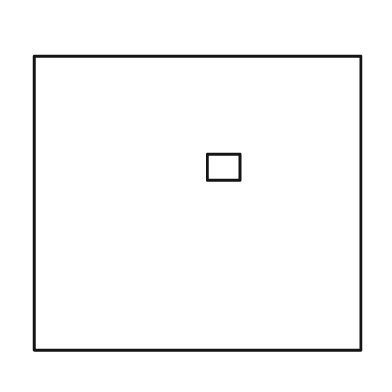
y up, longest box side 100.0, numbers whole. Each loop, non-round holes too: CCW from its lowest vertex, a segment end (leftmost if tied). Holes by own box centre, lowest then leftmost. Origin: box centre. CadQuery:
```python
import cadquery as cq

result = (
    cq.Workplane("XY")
    .moveTo(-50.0, -45.0)
    .lineTo(50.0, -45.0)
    .lineTo(50.0, 45.0)
    .lineTo(-50.0, 45.0)
    .close()
    .moveTo(3.0, 7.0)
    .lineTo(13.0, 7.0)
    .lineTo(13.0, 15.0)
    .lineTo(3.0, 15.0)
    .close()
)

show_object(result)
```